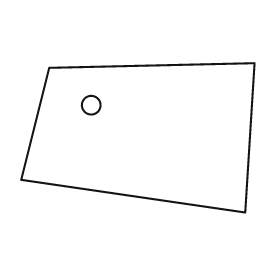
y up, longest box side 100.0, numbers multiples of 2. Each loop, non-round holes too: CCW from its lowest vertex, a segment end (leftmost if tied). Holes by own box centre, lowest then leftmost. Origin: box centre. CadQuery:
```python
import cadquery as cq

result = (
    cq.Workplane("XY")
    .moveTo(46.0, -32.0)
    .lineTo(50.0, 32.0)
    .lineTo(-38.0, 30.0)
    .lineTo(-50.0, -18.0)
    .close()
    .moveTo(-20.0, 14.0)
    .circle(4.0)
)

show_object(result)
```